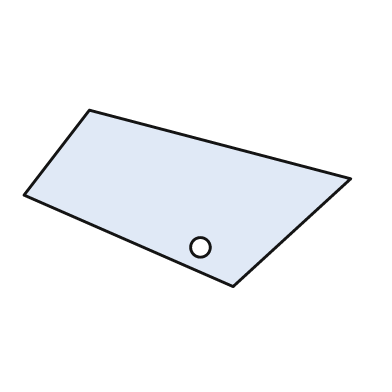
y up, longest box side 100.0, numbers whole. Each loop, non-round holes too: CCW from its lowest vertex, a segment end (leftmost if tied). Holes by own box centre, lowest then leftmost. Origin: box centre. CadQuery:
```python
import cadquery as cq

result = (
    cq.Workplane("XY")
    .moveTo(14.0, -27.0)
    .lineTo(50.0, 6.0)
    .lineTo(-30.0, 27.0)
    .lineTo(-50.0, 1.0)
    .close()
    .moveTo(4.0, -15.0)
    .circle(3.0)
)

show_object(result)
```